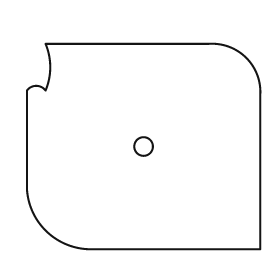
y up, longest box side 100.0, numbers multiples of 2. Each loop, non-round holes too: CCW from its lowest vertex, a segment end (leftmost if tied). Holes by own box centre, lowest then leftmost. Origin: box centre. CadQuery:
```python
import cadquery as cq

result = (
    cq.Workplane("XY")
    .moveTo(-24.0, -44.0)
    .lineTo(50.0, -44.0)
    .lineTo(50.0, 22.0)
    .threePointArc((44.0, 38.0), (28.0, 44.0))
    .lineTo(-42.0, 44.0)
    .threePointArc((-40.0, 34.0), (-42.0, 24.0))
    .threePointArc((-46.0, 26.0), (-50.0, 24.0))
    .lineTo(-50.0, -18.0)
    .threePointArc((-42.0, -36.0), (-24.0, -44.0))
    .close()
    .moveTo(0.0, 0.0)
    .circle(4.0)
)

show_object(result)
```